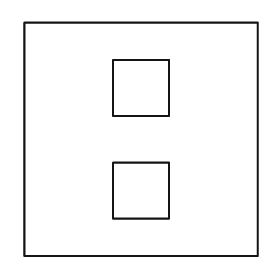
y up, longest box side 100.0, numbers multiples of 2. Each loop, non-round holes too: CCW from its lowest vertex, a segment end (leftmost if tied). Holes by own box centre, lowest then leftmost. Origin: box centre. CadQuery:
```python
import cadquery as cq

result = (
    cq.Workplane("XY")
    .moveTo(-50.0, -50.0)
    .lineTo(50.0, -50.0)
    .lineTo(50.0, 50.0)
    .lineTo(-50.0, 50.0)
    .close()
    .moveTo(-12.0, -34.0)
    .lineTo(12.0, -34.0)
    .lineTo(12.0, -10.0)
    .lineTo(-12.0, -10.0)
    .close()
    .moveTo(-12.0, 10.0)
    .lineTo(12.0, 10.0)
    .lineTo(12.0, 34.0)
    .lineTo(-12.0, 34.0)
    .close()
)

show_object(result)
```